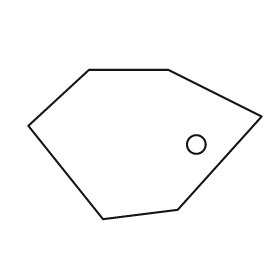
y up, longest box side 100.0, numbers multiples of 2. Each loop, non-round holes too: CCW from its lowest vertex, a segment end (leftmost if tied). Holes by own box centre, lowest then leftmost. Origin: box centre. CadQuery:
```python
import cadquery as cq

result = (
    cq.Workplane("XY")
    .moveTo(-18.0, -32.0)
    .lineTo(14.0, -28.0)
    .lineTo(50.0, 12.0)
    .lineTo(10.0, 32.0)
    .lineTo(-24.0, 32.0)
    .lineTo(-50.0, 8.0)
    .close()
    .moveTo(22.0, 0.0)
    .circle(4.0)
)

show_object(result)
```